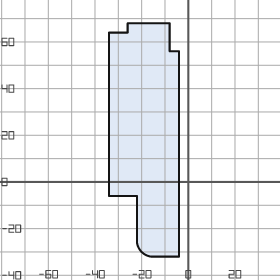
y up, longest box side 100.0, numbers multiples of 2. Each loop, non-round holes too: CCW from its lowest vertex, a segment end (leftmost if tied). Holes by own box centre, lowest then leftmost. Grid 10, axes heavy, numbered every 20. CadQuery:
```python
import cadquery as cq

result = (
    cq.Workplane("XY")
    .moveTo(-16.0, -32.0)
    .lineTo(-4.0, -32.0)
    .lineTo(-4.0, 56.0)
    .lineTo(-8.0, 56.0)
    .lineTo(-8.0, 68.0)
    .lineTo(-26.0, 68.0)
    .lineTo(-26.0, 64.0)
    .lineTo(-34.0, 64.0)
    .lineTo(-34.0, -6.0)
    .lineTo(-22.0, -6.0)
    .lineTo(-22.0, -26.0)
    .threePointArc((-20.0, -30.0), (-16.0, -32.0))
    .close()
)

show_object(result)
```